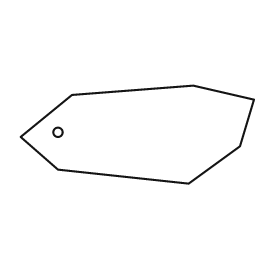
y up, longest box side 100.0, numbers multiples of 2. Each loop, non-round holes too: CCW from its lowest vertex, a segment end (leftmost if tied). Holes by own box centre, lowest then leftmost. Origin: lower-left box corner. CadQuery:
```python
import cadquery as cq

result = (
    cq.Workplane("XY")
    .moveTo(72.0, 0.0)
    .lineTo(94.0, 16.0)
    .lineTo(100.0, 36.0)
    .lineTo(74.0, 42.0)
    .lineTo(22.0, 38.0)
    .lineTo(0.0, 20.0)
    .lineTo(16.0, 6.0)
    .close()
    .moveTo(16.0, 22.0)
    .circle(2.0)
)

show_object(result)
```